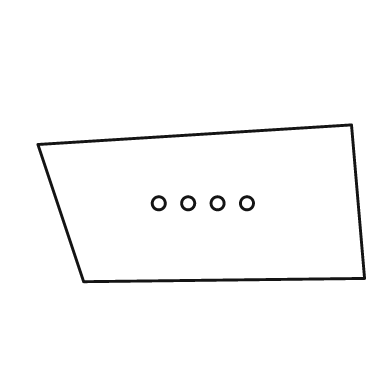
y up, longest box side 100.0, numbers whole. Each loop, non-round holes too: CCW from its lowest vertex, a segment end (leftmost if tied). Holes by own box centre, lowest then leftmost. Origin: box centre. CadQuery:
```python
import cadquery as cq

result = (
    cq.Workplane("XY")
    .moveTo(-36.0, -24.0)
    .lineTo(50.0, -23.0)
    .lineTo(46.0, 24.0)
    .lineTo(-50.0, 18.0)
    .close()
    .moveTo(-13.0, 0.0)
    .circle(2.0)
    .moveTo(-4.0, 0.0)
    .circle(2.0)
    .moveTo(5.0, 0.0)
    .circle(2.0)
    .moveTo(14.0, 0.0)
    .circle(2.0)
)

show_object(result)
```